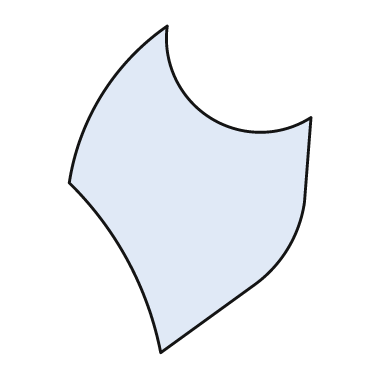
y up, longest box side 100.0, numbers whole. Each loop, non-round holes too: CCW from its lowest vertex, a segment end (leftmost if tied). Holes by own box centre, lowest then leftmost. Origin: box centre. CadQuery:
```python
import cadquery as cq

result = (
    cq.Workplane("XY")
    .moveTo(-9.0, -50.0)
    .lineTo(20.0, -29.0)
    .threePointArc((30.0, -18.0), (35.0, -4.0))
    .lineTo(37.0, 22.0)
    .threePointArc((6.0, 22.0), (-7.0, 50.0))
    .threePointArc((-27.0, 29.0), (-37.0, 2.0))
    .threePointArc((-19.0, -22.0), (-9.0, -50.0))
    .close()
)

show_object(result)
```